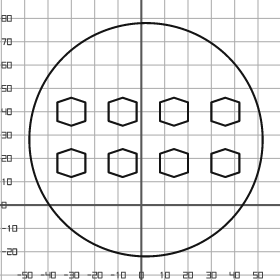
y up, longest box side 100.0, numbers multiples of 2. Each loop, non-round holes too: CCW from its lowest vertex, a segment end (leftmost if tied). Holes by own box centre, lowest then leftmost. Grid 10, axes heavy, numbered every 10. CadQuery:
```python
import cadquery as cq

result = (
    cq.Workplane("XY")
    .moveTo(2.0, 28.0)
    .circle(50.0)
    .moveTo(-30.0, 12.0)
    .lineTo(-24.0, 14.0)
    .lineTo(-24.0, 22.0)
    .lineTo(-30.0, 24.0)
    .lineTo(-36.0, 22.0)
    .lineTo(-36.0, 14.0)
    .close()
    .moveTo(-8.0, 12.0)
    .lineTo(-2.0, 14.0)
    .lineTo(-2.0, 22.0)
    .lineTo(-8.0, 24.0)
    .lineTo(-14.0, 22.0)
    .lineTo(-14.0, 14.0)
    .close()
    .moveTo(14.0, 12.0)
    .lineTo(20.0, 14.0)
    .lineTo(20.0, 22.0)
    .lineTo(14.0, 24.0)
    .lineTo(8.0, 22.0)
    .lineTo(8.0, 14.0)
    .close()
    .moveTo(36.0, 12.0)
    .lineTo(42.0, 14.0)
    .lineTo(42.0, 22.0)
    .lineTo(36.0, 24.0)
    .lineTo(30.0, 22.0)
    .lineTo(30.0, 14.0)
    .close()
    .moveTo(-30.0, 34.0)
    .lineTo(-24.0, 36.0)
    .lineTo(-24.0, 44.0)
    .lineTo(-30.0, 46.0)
    .lineTo(-36.0, 44.0)
    .lineTo(-36.0, 36.0)
    .close()
    .moveTo(-8.0, 34.0)
    .lineTo(-2.0, 36.0)
    .lineTo(-2.0, 44.0)
    .lineTo(-8.0, 46.0)
    .lineTo(-14.0, 44.0)
    .lineTo(-14.0, 36.0)
    .close()
    .moveTo(14.0, 34.0)
    .lineTo(20.0, 36.0)
    .lineTo(20.0, 44.0)
    .lineTo(14.0, 46.0)
    .lineTo(8.0, 44.0)
    .lineTo(8.0, 36.0)
    .close()
    .moveTo(36.0, 34.0)
    .lineTo(42.0, 36.0)
    .lineTo(42.0, 44.0)
    .lineTo(36.0, 46.0)
    .lineTo(30.0, 44.0)
    .lineTo(30.0, 36.0)
    .close()
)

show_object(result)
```